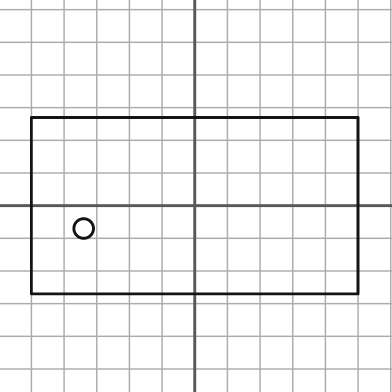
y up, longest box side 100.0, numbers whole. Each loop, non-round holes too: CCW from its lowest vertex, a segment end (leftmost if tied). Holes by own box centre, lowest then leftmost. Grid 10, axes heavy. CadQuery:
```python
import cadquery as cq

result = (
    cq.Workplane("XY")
    .moveTo(-50.0, -27.0)
    .lineTo(50.0, -27.0)
    .lineTo(50.0, 27.0)
    .lineTo(-50.0, 27.0)
    .close()
    .moveTo(-34.0, -7.0)
    .circle(3.0)
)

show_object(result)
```